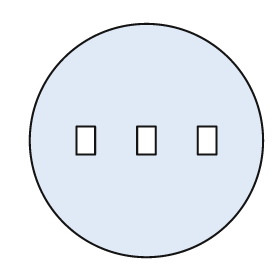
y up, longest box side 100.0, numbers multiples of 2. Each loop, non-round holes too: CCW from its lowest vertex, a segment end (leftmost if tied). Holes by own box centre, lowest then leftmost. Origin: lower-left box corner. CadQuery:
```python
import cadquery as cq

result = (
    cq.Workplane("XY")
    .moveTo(50.0, 50.0)
    .circle(50.0)
    .moveTo(20.0, 44.0)
    .lineTo(28.0, 44.0)
    .lineTo(28.0, 56.0)
    .lineTo(20.0, 56.0)
    .close()
    .moveTo(46.0, 44.0)
    .lineTo(54.0, 44.0)
    .lineTo(54.0, 56.0)
    .lineTo(46.0, 56.0)
    .close()
    .moveTo(72.0, 44.0)
    .lineTo(80.0, 44.0)
    .lineTo(80.0, 56.0)
    .lineTo(72.0, 56.0)
    .close()
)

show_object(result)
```